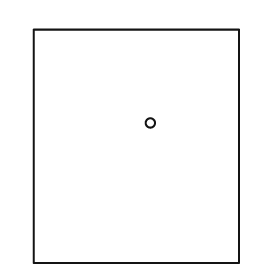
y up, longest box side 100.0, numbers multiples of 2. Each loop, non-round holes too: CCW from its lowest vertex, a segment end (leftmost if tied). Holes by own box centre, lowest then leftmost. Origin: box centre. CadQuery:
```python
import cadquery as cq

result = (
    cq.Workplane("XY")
    .moveTo(-44.0, -50.0)
    .lineTo(44.0, -50.0)
    .lineTo(44.0, 50.0)
    .lineTo(-44.0, 50.0)
    .close()
    .moveTo(6.0, 10.0)
    .circle(2.0)
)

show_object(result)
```